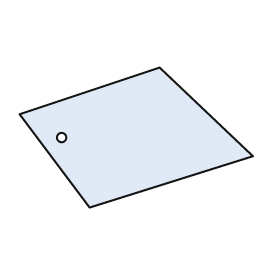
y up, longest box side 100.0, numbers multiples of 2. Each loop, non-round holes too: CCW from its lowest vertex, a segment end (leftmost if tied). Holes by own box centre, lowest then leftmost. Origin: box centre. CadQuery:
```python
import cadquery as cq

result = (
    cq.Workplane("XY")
    .moveTo(-20.0, -30.0)
    .lineTo(50.0, -8.0)
    .lineTo(10.0, 30.0)
    .lineTo(-50.0, 10.0)
    .close()
    .moveTo(-32.0, 0.0)
    .circle(2.0)
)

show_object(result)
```